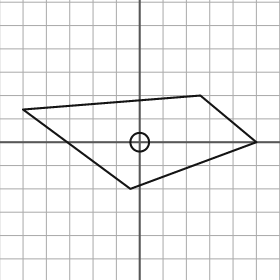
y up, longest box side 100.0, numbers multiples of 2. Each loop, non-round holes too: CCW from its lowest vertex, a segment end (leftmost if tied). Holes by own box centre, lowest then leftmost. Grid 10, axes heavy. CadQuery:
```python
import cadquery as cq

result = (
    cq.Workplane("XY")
    .moveTo(-4.0, -20.0)
    .lineTo(50.0, 0.0)
    .lineTo(26.0, 20.0)
    .lineTo(-50.0, 14.0)
    .close()
    .moveTo(0.0, 0.0)
    .circle(4.0)
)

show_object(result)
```